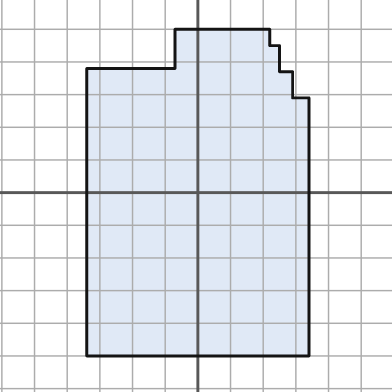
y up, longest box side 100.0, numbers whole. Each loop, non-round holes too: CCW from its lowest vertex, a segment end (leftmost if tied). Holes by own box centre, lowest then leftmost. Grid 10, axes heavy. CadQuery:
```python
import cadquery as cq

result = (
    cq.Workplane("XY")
    .moveTo(-34.0, -50.0)
    .lineTo(34.0, -50.0)
    .lineTo(34.0, 29.0)
    .lineTo(29.0, 29.0)
    .lineTo(29.0, 37.0)
    .lineTo(25.0, 37.0)
    .lineTo(25.0, 45.0)
    .lineTo(22.0, 45.0)
    .lineTo(22.0, 50.0)
    .lineTo(-7.0, 50.0)
    .lineTo(-7.0, 38.0)
    .lineTo(-34.0, 38.0)
    .close()
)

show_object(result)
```